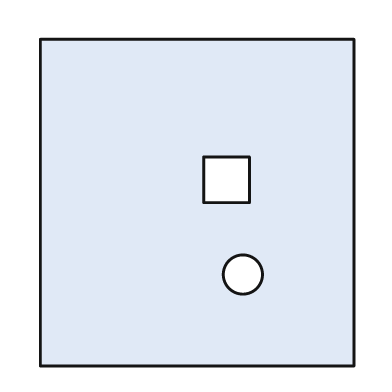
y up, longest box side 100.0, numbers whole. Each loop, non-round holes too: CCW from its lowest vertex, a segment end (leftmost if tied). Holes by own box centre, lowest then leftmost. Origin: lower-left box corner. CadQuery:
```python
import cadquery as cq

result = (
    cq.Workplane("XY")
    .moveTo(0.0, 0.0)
    .lineTo(96.0, 0.0)
    .lineTo(96.0, 100.0)
    .lineTo(0.0, 100.0)
    .close()
    .moveTo(62.0, 28.0)
    .circle(6.0)
    .moveTo(50.0, 50.0)
    .lineTo(64.0, 50.0)
    .lineTo(64.0, 64.0)
    .lineTo(50.0, 64.0)
    .close()
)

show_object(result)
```